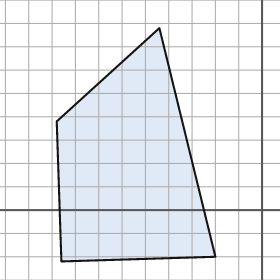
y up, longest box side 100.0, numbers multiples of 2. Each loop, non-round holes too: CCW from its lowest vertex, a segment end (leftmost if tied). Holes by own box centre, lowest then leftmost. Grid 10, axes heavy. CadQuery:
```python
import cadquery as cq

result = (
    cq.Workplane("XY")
    .moveTo(-86.0, -22.0)
    .lineTo(-20.0, -20.0)
    .lineTo(-44.0, 78.0)
    .lineTo(-88.0, 38.0)
    .close()
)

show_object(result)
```